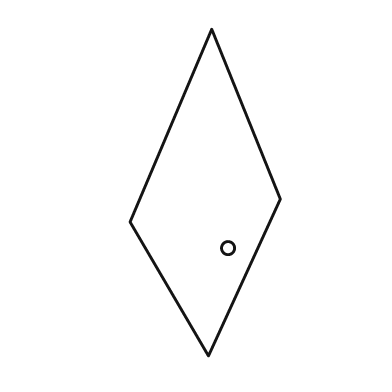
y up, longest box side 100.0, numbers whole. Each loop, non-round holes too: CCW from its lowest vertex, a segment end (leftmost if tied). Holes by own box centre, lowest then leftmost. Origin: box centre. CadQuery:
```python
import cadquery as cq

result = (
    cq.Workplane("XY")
    .moveTo(1.0, -50.0)
    .lineTo(23.0, -2.0)
    .lineTo(2.0, 50.0)
    .lineTo(-23.0, -9.0)
    .close()
    .moveTo(7.0, -17.0)
    .circle(2.0)
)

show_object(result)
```